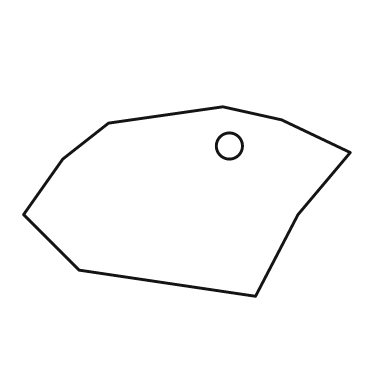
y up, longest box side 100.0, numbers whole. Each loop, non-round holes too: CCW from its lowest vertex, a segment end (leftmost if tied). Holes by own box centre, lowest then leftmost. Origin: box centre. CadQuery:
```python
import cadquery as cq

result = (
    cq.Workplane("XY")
    .moveTo(21.0, -29.0)
    .lineTo(34.0, -4.0)
    .lineTo(50.0, 15.0)
    .lineTo(29.0, 25.0)
    .lineTo(11.0, 29.0)
    .lineTo(-24.0, 24.0)
    .lineTo(-38.0, 13.0)
    .lineTo(-50.0, -4.0)
    .lineTo(-33.0, -21.0)
    .close()
    .moveTo(13.0, 17.0)
    .circle(4.0)
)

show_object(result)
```